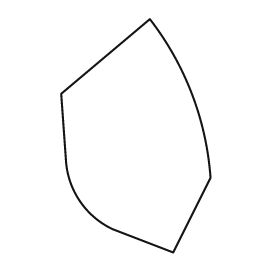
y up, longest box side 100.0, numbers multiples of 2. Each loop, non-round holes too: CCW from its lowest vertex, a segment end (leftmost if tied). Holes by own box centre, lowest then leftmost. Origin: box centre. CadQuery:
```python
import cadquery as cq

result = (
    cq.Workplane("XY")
    .moveTo(16.0, -50.0)
    .lineTo(32.0, -18.0)
    .threePointArc((24.0, 18.0), (6.0, 50.0))
    .lineTo(-32.0, 18.0)
    .lineTo(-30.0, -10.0)
    .threePointArc((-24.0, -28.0), (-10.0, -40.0))
    .close()
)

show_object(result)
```